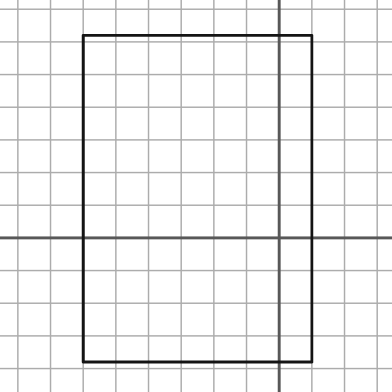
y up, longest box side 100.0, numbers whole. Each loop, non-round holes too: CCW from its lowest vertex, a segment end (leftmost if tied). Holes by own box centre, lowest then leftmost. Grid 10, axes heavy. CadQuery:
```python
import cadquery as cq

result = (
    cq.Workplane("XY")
    .moveTo(-60.0, -38.0)
    .lineTo(10.0, -38.0)
    .lineTo(10.0, 62.0)
    .lineTo(-60.0, 62.0)
    .close()
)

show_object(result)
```